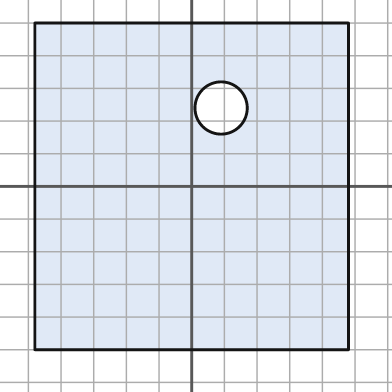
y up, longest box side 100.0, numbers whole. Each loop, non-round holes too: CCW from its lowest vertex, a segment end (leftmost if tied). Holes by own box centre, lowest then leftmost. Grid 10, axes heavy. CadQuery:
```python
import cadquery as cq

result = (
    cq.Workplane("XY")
    .moveTo(-48.0, -50.0)
    .lineTo(48.0, -50.0)
    .lineTo(48.0, 50.0)
    .lineTo(-48.0, 50.0)
    .close()
    .moveTo(9.0, 24.0)
    .circle(8.0)
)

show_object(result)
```